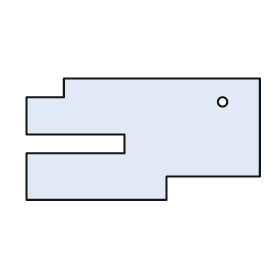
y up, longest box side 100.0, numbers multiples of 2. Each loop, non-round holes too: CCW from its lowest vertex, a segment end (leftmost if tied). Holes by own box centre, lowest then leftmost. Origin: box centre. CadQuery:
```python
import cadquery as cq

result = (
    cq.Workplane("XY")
    .moveTo(-50.0, -26.0)
    .lineTo(10.0, -26.0)
    .lineTo(10.0, -16.0)
    .lineTo(50.0, -16.0)
    .lineTo(50.0, 26.0)
    .lineTo(-34.0, 26.0)
    .lineTo(-34.0, 18.0)
    .lineTo(-50.0, 18.0)
    .lineTo(-50.0, 2.0)
    .lineTo(-8.0, 2.0)
    .lineTo(-8.0, -6.0)
    .lineTo(-50.0, -6.0)
    .close()
    .moveTo(34.0, 16.0)
    .circle(2.0)
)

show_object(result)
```